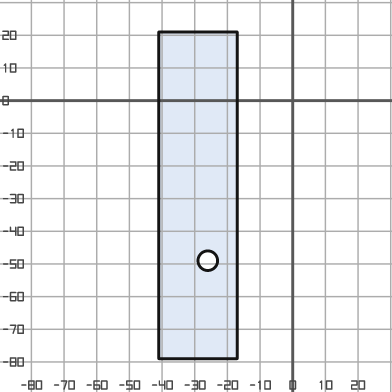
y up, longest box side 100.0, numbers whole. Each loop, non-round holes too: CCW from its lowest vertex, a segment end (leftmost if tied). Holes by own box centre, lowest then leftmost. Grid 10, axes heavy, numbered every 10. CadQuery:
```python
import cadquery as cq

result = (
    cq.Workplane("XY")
    .moveTo(-41.0, -79.0)
    .lineTo(-17.0, -79.0)
    .lineTo(-17.0, 21.0)
    .lineTo(-41.0, 21.0)
    .close()
    .moveTo(-26.0, -49.0)
    .circle(3.0)
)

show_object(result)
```